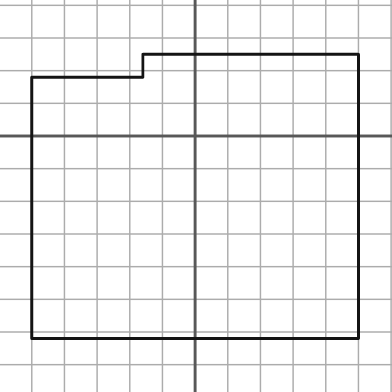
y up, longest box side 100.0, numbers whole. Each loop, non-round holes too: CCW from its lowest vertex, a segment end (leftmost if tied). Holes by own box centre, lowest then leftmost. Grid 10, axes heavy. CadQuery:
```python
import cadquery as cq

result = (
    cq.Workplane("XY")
    .moveTo(-50.0, -62.0)
    .lineTo(50.0, -62.0)
    .lineTo(50.0, 25.0)
    .lineTo(-16.0, 25.0)
    .lineTo(-16.0, 18.0)
    .lineTo(-50.0, 18.0)
    .close()
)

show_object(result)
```